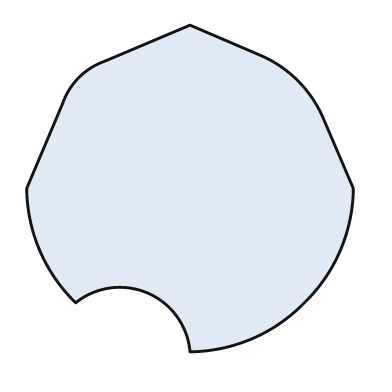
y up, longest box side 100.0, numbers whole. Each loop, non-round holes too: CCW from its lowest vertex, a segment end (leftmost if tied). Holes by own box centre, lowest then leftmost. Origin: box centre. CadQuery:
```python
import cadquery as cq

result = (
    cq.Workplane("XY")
    .moveTo(0.0, -50.0)
    .threePointArc((19.0, -46.0), (35.0, -35.0))
    .threePointArc((46.0, -19.0), (50.0, 0.0))
    .lineTo(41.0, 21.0)
    .threePointArc((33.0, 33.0), (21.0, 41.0))
    .lineTo(0.0, 50.0)
    .lineTo(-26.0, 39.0)
    .threePointArc((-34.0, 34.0), (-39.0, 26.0))
    .lineTo(-50.0, 0.0)
    .threePointArc((-46.0, -19.0), (-35.0, -35.0))
    .threePointArc((-13.0, -32.0), (0.0, -50.0))
    .close()
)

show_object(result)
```